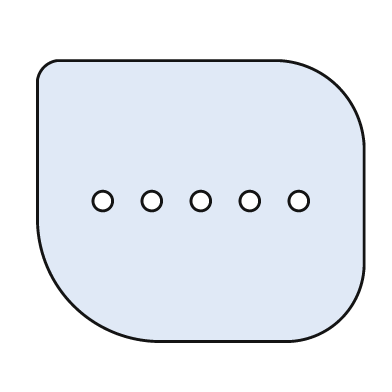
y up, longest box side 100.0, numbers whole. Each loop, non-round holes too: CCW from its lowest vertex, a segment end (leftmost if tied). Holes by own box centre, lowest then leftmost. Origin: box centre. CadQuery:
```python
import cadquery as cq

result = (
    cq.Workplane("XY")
    .moveTo(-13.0, -43.0)
    .lineTo(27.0, -43.0)
    .threePointArc((43.0, -36.0), (50.0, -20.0))
    .lineTo(50.0, 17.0)
    .threePointArc((42.0, 35.0), (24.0, 43.0))
    .lineTo(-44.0, 43.0)
    .threePointArc((-48.0, 41.0), (-50.0, 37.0))
    .lineTo(-50.0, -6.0)
    .threePointArc((-39.0, -32.0), (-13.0, -43.0))
    .close()
    .moveTo(-30.0, 0.0)
    .circle(3.0)
    .moveTo(-15.0, 0.0)
    .circle(3.0)
    .moveTo(0.0, 0.0)
    .circle(3.0)
    .moveTo(15.0, 0.0)
    .circle(3.0)
    .moveTo(30.0, 0.0)
    .circle(3.0)
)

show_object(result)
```